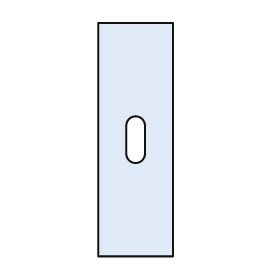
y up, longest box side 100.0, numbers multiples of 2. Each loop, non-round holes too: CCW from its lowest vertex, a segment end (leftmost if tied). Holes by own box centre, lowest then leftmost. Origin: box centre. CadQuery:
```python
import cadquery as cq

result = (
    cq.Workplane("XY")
    .moveTo(-16.0, -50.0)
    .lineTo(16.0, -50.0)
    .lineTo(16.0, 50.0)
    .lineTo(-16.0, 50.0)
    .close()
    .moveTo(-4.0, -6.0)
    .threePointArc((0.0, -10.0), (4.0, -6.0))
    .lineTo(4.0, 6.0)
    .threePointArc((0.0, 10.0), (-4.0, 6.0))
    .close()
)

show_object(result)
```